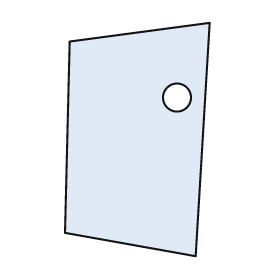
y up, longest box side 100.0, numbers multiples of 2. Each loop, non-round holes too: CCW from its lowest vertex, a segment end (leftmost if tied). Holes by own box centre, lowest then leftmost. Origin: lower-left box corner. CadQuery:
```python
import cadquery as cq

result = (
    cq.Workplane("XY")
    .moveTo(56.0, 0.0)
    .lineTo(62.0, 100.0)
    .lineTo(2.0, 92.0)
    .lineTo(0.0, 10.0)
    .close()
    .moveTo(48.0, 68.0)
    .circle(6.0)
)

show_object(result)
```